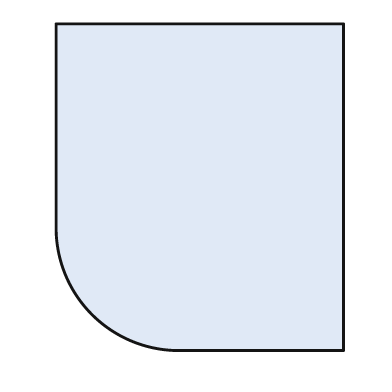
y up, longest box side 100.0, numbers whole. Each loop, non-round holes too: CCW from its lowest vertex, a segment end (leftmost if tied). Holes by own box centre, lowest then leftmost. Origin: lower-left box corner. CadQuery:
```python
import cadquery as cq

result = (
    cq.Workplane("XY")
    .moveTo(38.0, 0.0)
    .lineTo(88.0, 0.0)
    .lineTo(88.0, 100.0)
    .lineTo(0.0, 100.0)
    .lineTo(0.0, 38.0)
    .threePointArc((11.0, 11.0), (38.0, 0.0))
    .close()
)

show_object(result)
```